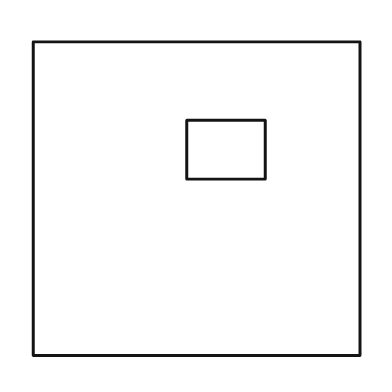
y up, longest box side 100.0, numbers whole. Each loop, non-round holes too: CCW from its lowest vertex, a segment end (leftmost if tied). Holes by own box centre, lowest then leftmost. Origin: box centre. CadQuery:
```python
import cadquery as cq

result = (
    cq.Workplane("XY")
    .moveTo(-50.0, -48.0)
    .lineTo(50.0, -48.0)
    .lineTo(50.0, 48.0)
    .lineTo(-50.0, 48.0)
    .close()
    .moveTo(-3.0, 6.0)
    .lineTo(21.0, 6.0)
    .lineTo(21.0, 24.0)
    .lineTo(-3.0, 24.0)
    .close()
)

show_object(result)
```